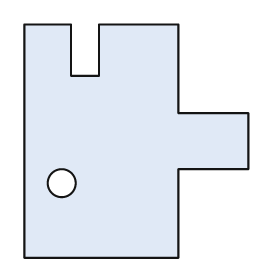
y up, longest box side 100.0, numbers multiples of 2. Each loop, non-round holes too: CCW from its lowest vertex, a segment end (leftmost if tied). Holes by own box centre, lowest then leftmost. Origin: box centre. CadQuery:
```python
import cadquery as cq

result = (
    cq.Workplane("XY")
    .moveTo(-48.0, -50.0)
    .lineTo(18.0, -50.0)
    .lineTo(18.0, -12.0)
    .lineTo(48.0, -12.0)
    .lineTo(48.0, 12.0)
    .lineTo(18.0, 12.0)
    .lineTo(18.0, 50.0)
    .lineTo(-16.0, 50.0)
    .lineTo(-16.0, 28.0)
    .lineTo(-28.0, 28.0)
    .lineTo(-28.0, 50.0)
    .lineTo(-48.0, 50.0)
    .close()
    .moveTo(-32.0, -18.0)
    .circle(6.0)
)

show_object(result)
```